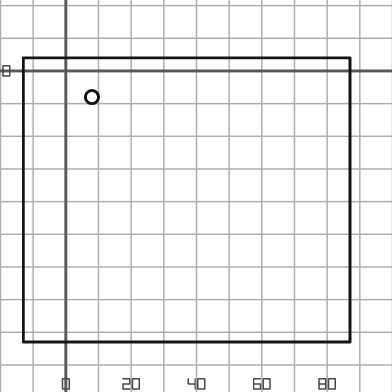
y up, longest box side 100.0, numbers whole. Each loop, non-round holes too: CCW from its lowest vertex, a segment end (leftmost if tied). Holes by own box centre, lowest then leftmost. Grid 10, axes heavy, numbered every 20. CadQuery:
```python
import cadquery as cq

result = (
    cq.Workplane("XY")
    .moveTo(-13.0, -83.0)
    .lineTo(87.0, -83.0)
    .lineTo(87.0, 4.0)
    .lineTo(-13.0, 4.0)
    .close()
    .moveTo(8.0, -8.0)
    .circle(2.0)
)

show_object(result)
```